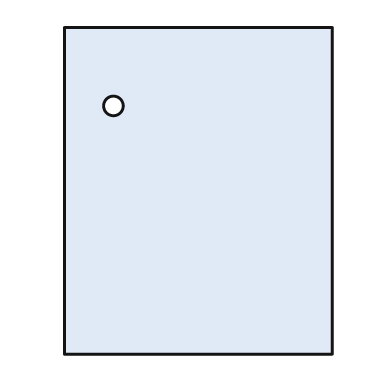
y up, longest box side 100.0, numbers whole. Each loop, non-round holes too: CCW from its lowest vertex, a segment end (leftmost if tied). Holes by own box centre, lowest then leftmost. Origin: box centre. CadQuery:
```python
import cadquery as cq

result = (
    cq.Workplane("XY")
    .moveTo(-41.0, -50.0)
    .lineTo(41.0, -50.0)
    .lineTo(41.0, 50.0)
    .lineTo(-41.0, 50.0)
    .close()
    .moveTo(-26.0, 26.0)
    .circle(3.0)
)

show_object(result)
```